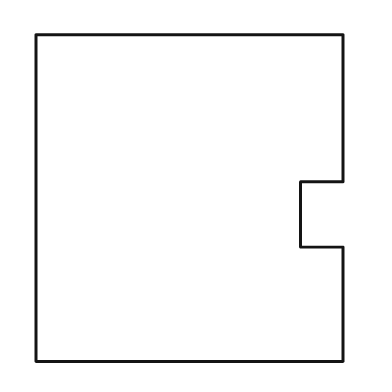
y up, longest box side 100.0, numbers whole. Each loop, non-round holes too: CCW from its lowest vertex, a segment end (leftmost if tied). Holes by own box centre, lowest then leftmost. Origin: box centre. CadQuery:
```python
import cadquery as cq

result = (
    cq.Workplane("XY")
    .moveTo(-47.0, -50.0)
    .lineTo(47.0, -50.0)
    .lineTo(47.0, -15.0)
    .lineTo(34.0, -15.0)
    .lineTo(34.0, 5.0)
    .lineTo(47.0, 5.0)
    .lineTo(47.0, 50.0)
    .lineTo(-47.0, 50.0)
    .close()
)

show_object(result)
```